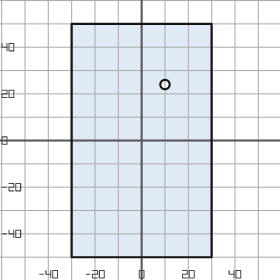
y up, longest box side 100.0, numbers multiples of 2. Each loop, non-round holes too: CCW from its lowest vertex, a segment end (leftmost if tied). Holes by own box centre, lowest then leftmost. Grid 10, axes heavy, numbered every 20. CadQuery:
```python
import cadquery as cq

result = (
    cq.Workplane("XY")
    .moveTo(-30.0, -50.0)
    .lineTo(30.0, -50.0)
    .lineTo(30.0, 50.0)
    .lineTo(-30.0, 50.0)
    .close()
    .moveTo(10.0, 24.0)
    .circle(2.0)
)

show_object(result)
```